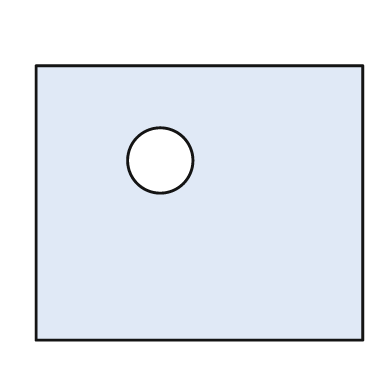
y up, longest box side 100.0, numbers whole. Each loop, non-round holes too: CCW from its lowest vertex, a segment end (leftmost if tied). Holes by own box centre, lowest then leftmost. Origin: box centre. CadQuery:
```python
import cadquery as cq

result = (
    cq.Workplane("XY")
    .moveTo(-50.0, -42.0)
    .lineTo(50.0, -42.0)
    .lineTo(50.0, 42.0)
    .lineTo(-50.0, 42.0)
    .close()
    .moveTo(-12.0, 13.0)
    .circle(10.0)
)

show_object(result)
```